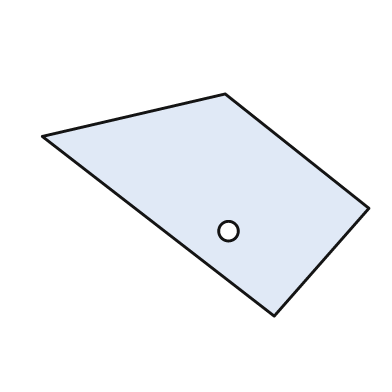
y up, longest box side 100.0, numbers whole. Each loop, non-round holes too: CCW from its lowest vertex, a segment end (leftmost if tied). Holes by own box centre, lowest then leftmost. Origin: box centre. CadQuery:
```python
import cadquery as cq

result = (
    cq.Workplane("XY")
    .moveTo(21.0, -34.0)
    .lineTo(50.0, -1.0)
    .lineTo(6.0, 34.0)
    .lineTo(-50.0, 21.0)
    .close()
    .moveTo(7.0, -8.0)
    .circle(3.0)
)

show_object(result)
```